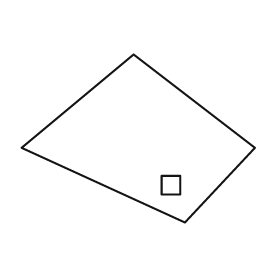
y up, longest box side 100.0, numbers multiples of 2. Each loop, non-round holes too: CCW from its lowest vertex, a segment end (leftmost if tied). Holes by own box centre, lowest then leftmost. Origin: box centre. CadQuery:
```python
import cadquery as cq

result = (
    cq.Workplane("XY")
    .moveTo(20.0, -36.0)
    .lineTo(50.0, -4.0)
    .lineTo(-2.0, 36.0)
    .lineTo(-50.0, -4.0)
    .close()
    .moveTo(10.0, -24.0)
    .lineTo(18.0, -24.0)
    .lineTo(18.0, -16.0)
    .lineTo(10.0, -16.0)
    .close()
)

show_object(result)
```